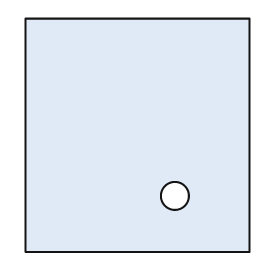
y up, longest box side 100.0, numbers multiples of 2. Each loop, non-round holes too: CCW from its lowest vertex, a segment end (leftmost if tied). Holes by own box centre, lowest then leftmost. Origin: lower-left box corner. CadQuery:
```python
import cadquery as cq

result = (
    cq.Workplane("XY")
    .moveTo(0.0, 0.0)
    .lineTo(96.0, 0.0)
    .lineTo(96.0, 100.0)
    .lineTo(0.0, 100.0)
    .close()
    .moveTo(64.0, 24.0)
    .circle(6.0)
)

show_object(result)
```